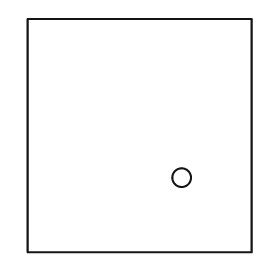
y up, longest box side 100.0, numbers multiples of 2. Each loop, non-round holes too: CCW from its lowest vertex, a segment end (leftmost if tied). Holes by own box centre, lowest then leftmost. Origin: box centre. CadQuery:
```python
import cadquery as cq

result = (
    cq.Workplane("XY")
    .moveTo(-48.0, -50.0)
    .lineTo(48.0, -50.0)
    .lineTo(48.0, 50.0)
    .lineTo(-48.0, 50.0)
    .close()
    .moveTo(18.0, -18.0)
    .circle(4.0)
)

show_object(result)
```